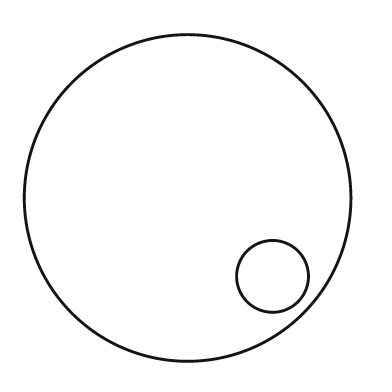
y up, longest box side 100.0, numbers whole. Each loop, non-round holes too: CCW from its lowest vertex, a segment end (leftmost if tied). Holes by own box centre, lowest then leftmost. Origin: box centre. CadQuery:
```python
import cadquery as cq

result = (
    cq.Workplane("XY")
    .moveTo(0.0, 0.0)
    .circle(50.0)
    .moveTo(26.0, -24.0)
    .circle(11.0)
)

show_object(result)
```